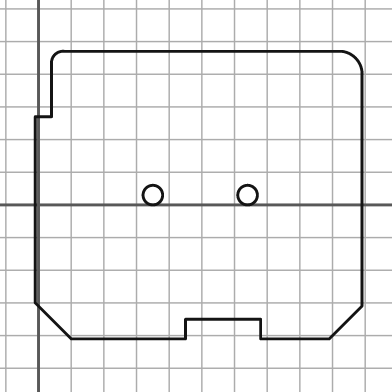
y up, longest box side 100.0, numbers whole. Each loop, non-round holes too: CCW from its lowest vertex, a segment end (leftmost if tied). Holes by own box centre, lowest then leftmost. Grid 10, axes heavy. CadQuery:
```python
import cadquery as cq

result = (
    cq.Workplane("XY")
    .moveTo(10.0, -41.0)
    .lineTo(45.0, -41.0)
    .lineTo(45.0, -35.0)
    .lineTo(68.0, -35.0)
    .lineTo(68.0, -41.0)
    .lineTo(89.0, -41.0)
    .lineTo(99.0, -31.0)
    .lineTo(99.0, 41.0)
    .threePointArc((97.0, 45.0), (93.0, 47.0))
    .lineTo(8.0, 47.0)
    .threePointArc((5.0, 46.0), (4.0, 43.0))
    .lineTo(4.0, 27.0)
    .lineTo(-1.0, 27.0)
    .lineTo(-1.0, -30.0)
    .close()
    .moveTo(35.0, 3.0)
    .circle(3.0)
    .moveTo(64.0, 3.0)
    .circle(3.0)
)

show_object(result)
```